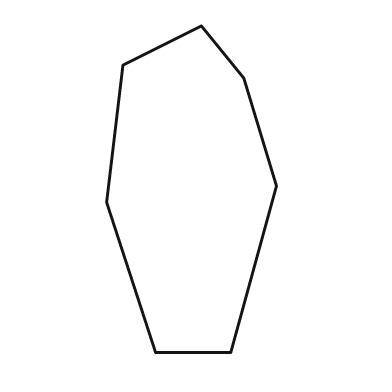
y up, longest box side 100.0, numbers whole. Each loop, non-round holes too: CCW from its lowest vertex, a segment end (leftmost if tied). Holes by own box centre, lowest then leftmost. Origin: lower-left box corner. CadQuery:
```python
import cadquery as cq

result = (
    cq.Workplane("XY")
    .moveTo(15.0, 0.0)
    .lineTo(38.0, 0.0)
    .lineTo(52.0, 51.0)
    .lineTo(42.0, 84.0)
    .lineTo(29.0, 100.0)
    .lineTo(5.0, 88.0)
    .lineTo(0.0, 46.0)
    .close()
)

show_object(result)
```